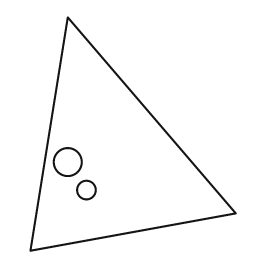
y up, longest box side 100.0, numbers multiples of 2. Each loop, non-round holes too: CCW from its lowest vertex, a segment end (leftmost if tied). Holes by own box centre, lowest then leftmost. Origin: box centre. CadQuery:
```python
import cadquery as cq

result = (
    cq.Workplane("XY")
    .moveTo(-44.0, -50.0)
    .lineTo(44.0, -34.0)
    .lineTo(-28.0, 50.0)
    .close()
    .moveTo(-20.0, -24.0)
    .circle(4.0)
    .moveTo(-28.0, -12.0)
    .circle(6.0)
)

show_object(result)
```